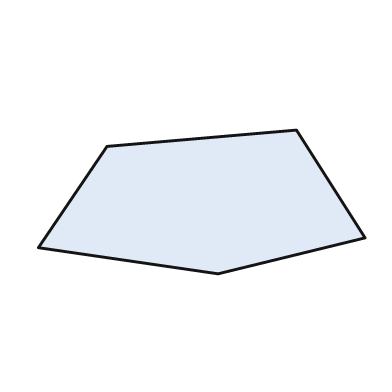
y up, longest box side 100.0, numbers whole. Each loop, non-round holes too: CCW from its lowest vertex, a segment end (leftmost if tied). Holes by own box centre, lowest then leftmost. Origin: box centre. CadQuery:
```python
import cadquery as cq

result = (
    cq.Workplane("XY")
    .moveTo(5.0, -22.0)
    .lineTo(50.0, -11.0)
    .lineTo(29.0, 22.0)
    .lineTo(-29.0, 17.0)
    .lineTo(-50.0, -14.0)
    .close()
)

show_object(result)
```